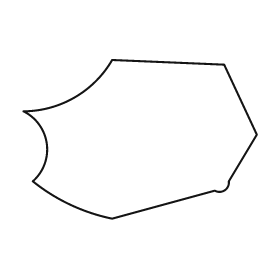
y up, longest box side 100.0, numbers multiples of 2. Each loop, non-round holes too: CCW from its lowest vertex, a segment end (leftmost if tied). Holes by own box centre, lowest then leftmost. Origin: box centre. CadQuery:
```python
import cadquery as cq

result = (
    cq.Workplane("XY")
    .moveTo(-12.0, -34.0)
    .lineTo(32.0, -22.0)
    .threePointArc((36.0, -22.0), (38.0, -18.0))
    .lineTo(50.0, 2.0)
    .lineTo(36.0, 32.0)
    .lineTo(-12.0, 34.0)
    .threePointArc((-28.0, 18.0), (-50.0, 12.0))
    .threePointArc((-40.0, -2.0), (-46.0, -18.0))
    .threePointArc((-30.0, -28.0), (-12.0, -34.0))
    .close()
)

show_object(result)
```